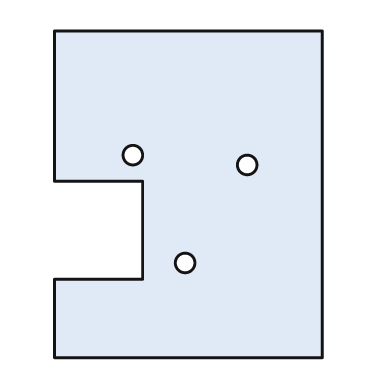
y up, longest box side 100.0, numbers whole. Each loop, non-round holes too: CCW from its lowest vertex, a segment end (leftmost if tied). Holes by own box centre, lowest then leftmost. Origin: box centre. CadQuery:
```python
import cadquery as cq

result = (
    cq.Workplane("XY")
    .moveTo(-41.0, -50.0)
    .lineTo(41.0, -50.0)
    .lineTo(41.0, 50.0)
    .lineTo(-41.0, 50.0)
    .lineTo(-41.0, 4.0)
    .lineTo(-14.0, 4.0)
    .lineTo(-14.0, -26.0)
    .lineTo(-41.0, -26.0)
    .close()
    .moveTo(-1.0, -21.0)
    .circle(3.0)
    .moveTo(18.0, 9.0)
    .circle(3.0)
    .moveTo(-17.0, 12.0)
    .circle(3.0)
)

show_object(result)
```